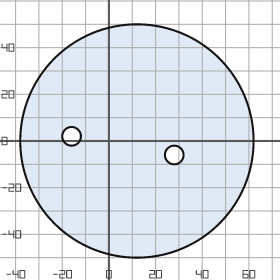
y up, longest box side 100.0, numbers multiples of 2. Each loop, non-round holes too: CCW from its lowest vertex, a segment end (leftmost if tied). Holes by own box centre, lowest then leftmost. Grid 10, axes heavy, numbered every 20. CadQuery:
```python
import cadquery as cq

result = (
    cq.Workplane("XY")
    .moveTo(12.0, 0.0)
    .circle(50.0)
    .moveTo(28.0, -6.0)
    .circle(4.0)
    .moveTo(-16.0, 2.0)
    .circle(4.0)
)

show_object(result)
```